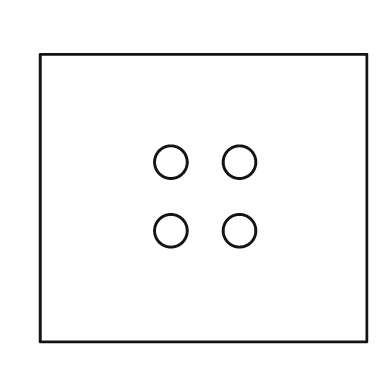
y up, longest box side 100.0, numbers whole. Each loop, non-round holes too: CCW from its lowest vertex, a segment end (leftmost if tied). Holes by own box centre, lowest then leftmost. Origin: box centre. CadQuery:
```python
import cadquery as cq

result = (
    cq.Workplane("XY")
    .moveTo(-50.0, -44.0)
    .lineTo(50.0, -44.0)
    .lineTo(50.0, 44.0)
    .lineTo(-50.0, 44.0)
    .close()
    .moveTo(-10.0, -10.0)
    .circle(5.0)
    .moveTo(11.0, -10.0)
    .circle(5.0)
    .moveTo(-10.0, 11.0)
    .circle(5.0)
    .moveTo(11.0, 11.0)
    .circle(5.0)
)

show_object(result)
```